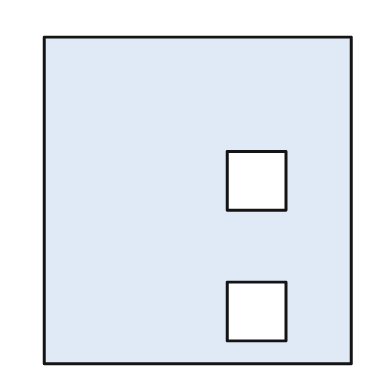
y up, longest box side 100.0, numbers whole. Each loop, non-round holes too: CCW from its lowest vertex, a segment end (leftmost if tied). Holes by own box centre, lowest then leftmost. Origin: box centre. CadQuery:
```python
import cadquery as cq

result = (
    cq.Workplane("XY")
    .moveTo(-47.0, -50.0)
    .lineTo(47.0, -50.0)
    .lineTo(47.0, 50.0)
    .lineTo(-47.0, 50.0)
    .close()
    .moveTo(9.0, -43.0)
    .lineTo(27.0, -43.0)
    .lineTo(27.0, -25.0)
    .lineTo(9.0, -25.0)
    .close()
    .moveTo(9.0, -3.0)
    .lineTo(27.0, -3.0)
    .lineTo(27.0, 15.0)
    .lineTo(9.0, 15.0)
    .close()
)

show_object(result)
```